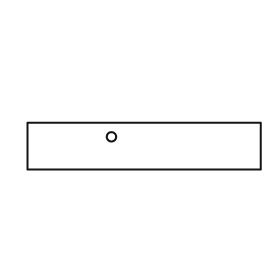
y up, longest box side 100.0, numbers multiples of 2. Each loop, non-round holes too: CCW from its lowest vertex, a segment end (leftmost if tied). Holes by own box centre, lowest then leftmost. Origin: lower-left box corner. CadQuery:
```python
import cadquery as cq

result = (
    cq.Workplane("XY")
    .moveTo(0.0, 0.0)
    .lineTo(100.0, 0.0)
    .lineTo(100.0, 20.0)
    .lineTo(0.0, 20.0)
    .close()
    .moveTo(36.0, 14.0)
    .circle(2.0)
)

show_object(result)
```